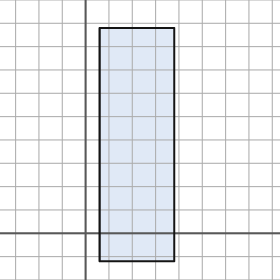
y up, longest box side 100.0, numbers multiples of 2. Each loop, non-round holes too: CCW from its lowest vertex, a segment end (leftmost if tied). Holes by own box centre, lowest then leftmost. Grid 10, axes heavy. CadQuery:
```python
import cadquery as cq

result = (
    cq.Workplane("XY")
    .moveTo(6.0, -12.0)
    .lineTo(38.0, -12.0)
    .lineTo(38.0, 88.0)
    .lineTo(6.0, 88.0)
    .close()
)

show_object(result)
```